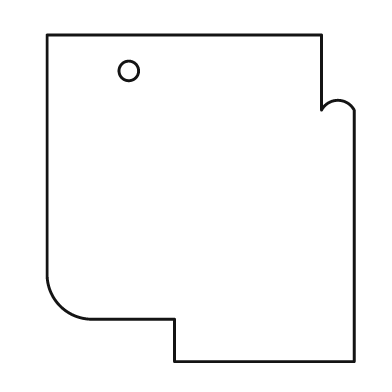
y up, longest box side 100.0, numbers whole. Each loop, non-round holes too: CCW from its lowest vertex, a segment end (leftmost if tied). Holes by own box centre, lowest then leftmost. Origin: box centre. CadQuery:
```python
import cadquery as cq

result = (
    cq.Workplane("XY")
    .moveTo(-8.0, -50.0)
    .lineTo(47.0, -50.0)
    .lineTo(47.0, 27.0)
    .threePointArc((42.0, 30.0), (37.0, 27.0))
    .lineTo(37.0, 50.0)
    .lineTo(-47.0, 50.0)
    .lineTo(-47.0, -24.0)
    .threePointArc((-43.0, -33.0), (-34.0, -37.0))
    .lineTo(-8.0, -37.0)
    .close()
    .moveTo(-22.0, 39.0)
    .circle(3.0)
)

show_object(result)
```